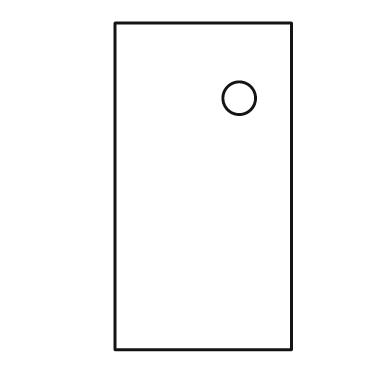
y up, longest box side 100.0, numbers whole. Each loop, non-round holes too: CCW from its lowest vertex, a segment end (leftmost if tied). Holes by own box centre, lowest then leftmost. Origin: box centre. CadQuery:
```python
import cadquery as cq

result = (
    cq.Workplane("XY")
    .moveTo(-27.0, -50.0)
    .lineTo(27.0, -50.0)
    .lineTo(27.0, 50.0)
    .lineTo(-27.0, 50.0)
    .close()
    .moveTo(11.0, 27.0)
    .circle(5.0)
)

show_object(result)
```